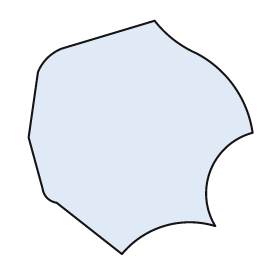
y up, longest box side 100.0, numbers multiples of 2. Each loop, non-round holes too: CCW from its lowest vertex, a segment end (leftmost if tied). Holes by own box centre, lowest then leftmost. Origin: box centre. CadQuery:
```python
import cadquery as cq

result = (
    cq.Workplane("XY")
    .moveTo(-8.0, -50.0)
    .threePointArc((10.0, -38.0), (32.0, -38.0))
    .threePointArc((30.0, -14.0), (48.0, 2.0))
    .threePointArc((40.0, 22.0), (24.0, 36.0))
    .threePointArc((14.0, 42.0), (6.0, 50.0))
    .lineTo(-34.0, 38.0)
    .threePointArc((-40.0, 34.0), (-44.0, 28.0))
    .lineTo(-48.0, 0.0)
    .lineTo(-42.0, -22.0)
    .threePointArc((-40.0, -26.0), (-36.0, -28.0))
    .close()
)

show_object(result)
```